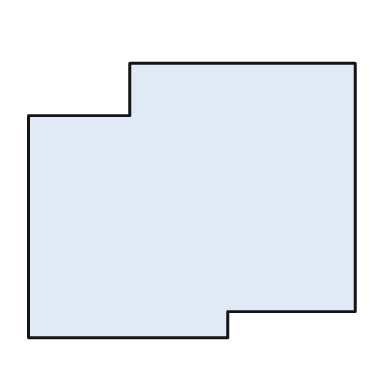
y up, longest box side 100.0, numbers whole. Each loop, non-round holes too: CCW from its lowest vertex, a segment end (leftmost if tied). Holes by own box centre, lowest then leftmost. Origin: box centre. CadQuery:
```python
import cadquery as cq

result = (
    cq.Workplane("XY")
    .moveTo(-50.0, -42.0)
    .lineTo(11.0, -42.0)
    .lineTo(11.0, -34.0)
    .lineTo(50.0, -34.0)
    .lineTo(50.0, 42.0)
    .lineTo(-19.0, 42.0)
    .lineTo(-19.0, 26.0)
    .lineTo(-50.0, 26.0)
    .close()
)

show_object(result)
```